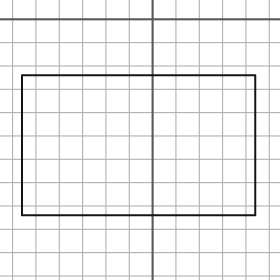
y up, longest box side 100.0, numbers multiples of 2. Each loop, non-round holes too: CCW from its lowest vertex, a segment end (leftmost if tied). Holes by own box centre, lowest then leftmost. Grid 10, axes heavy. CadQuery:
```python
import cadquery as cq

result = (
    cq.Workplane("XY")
    .moveTo(-56.0, -84.0)
    .lineTo(44.0, -84.0)
    .lineTo(44.0, -24.0)
    .lineTo(-56.0, -24.0)
    .close()
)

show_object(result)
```